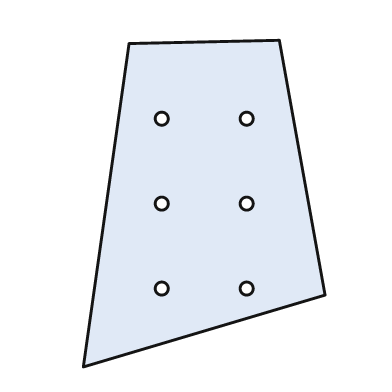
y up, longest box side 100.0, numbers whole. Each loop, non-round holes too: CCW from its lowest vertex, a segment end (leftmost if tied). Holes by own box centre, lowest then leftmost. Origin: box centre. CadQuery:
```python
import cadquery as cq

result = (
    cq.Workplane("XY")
    .moveTo(-37.0, -50.0)
    .lineTo(37.0, -28.0)
    .lineTo(23.0, 50.0)
    .lineTo(-23.0, 49.0)
    .close()
    .moveTo(-13.0, -26.0)
    .circle(2.0)
    .moveTo(13.0, -26.0)
    .circle(2.0)
    .moveTo(-13.0, 0.0)
    .circle(2.0)
    .moveTo(13.0, 0.0)
    .circle(2.0)
    .moveTo(-13.0, 26.0)
    .circle(2.0)
    .moveTo(13.0, 26.0)
    .circle(2.0)
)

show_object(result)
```